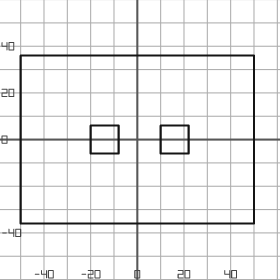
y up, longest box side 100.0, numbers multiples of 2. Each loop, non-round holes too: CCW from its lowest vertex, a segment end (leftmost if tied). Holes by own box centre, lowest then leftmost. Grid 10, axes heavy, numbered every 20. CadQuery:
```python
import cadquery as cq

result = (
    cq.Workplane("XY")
    .moveTo(-50.0, -36.0)
    .lineTo(50.0, -36.0)
    .lineTo(50.0, 36.0)
    .lineTo(-50.0, 36.0)
    .close()
    .moveTo(-20.0, -6.0)
    .lineTo(-8.0, -6.0)
    .lineTo(-8.0, 6.0)
    .lineTo(-20.0, 6.0)
    .close()
    .moveTo(10.0, -6.0)
    .lineTo(22.0, -6.0)
    .lineTo(22.0, 6.0)
    .lineTo(10.0, 6.0)
    .close()
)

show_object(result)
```